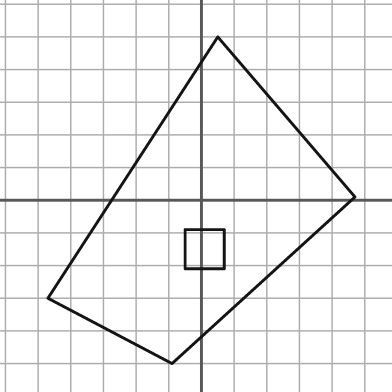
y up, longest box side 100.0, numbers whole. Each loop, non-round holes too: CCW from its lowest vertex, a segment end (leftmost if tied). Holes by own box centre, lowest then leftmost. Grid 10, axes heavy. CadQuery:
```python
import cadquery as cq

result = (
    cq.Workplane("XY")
    .moveTo(-9.0, -50.0)
    .lineTo(47.0, 1.0)
    .lineTo(5.0, 50.0)
    .lineTo(-47.0, -30.0)
    .close()
    .moveTo(-5.0, -21.0)
    .lineTo(7.0, -21.0)
    .lineTo(7.0, -9.0)
    .lineTo(-5.0, -9.0)
    .close()
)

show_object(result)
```